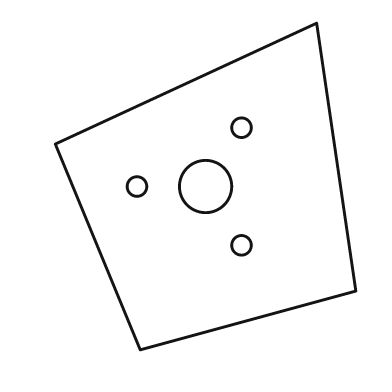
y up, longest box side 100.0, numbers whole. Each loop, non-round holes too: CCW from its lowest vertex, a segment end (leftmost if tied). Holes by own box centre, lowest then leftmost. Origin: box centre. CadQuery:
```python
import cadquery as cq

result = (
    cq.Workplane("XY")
    .moveTo(-20.0, -50.0)
    .lineTo(46.0, -32.0)
    .lineTo(34.0, 50.0)
    .lineTo(-46.0, 13.0)
    .close()
    .moveTo(11.0, -18.0)
    .circle(3.0)
    .moveTo(-21.0, 0.0)
    .circle(3.0)
    .moveTo(0.0, 0.0)
    .circle(8.0)
    .moveTo(11.0, 18.0)
    .circle(3.0)
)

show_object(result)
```